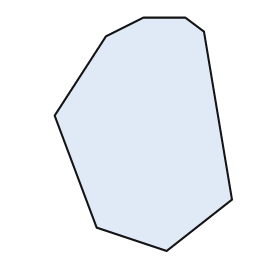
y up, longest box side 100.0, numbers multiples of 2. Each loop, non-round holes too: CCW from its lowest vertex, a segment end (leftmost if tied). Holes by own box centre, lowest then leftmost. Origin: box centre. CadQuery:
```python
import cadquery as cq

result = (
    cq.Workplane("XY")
    .moveTo(10.0, -50.0)
    .lineTo(38.0, -28.0)
    .lineTo(26.0, 44.0)
    .lineTo(18.0, 50.0)
    .lineTo(0.0, 50.0)
    .lineTo(-16.0, 42.0)
    .lineTo(-38.0, 8.0)
    .lineTo(-20.0, -40.0)
    .close()
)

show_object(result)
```